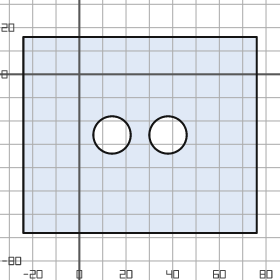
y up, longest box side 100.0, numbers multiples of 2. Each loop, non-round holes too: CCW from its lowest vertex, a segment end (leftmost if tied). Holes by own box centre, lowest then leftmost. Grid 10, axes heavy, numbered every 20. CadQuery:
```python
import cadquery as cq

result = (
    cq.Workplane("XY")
    .moveTo(-24.0, -68.0)
    .lineTo(76.0, -68.0)
    .lineTo(76.0, 16.0)
    .lineTo(-24.0, 16.0)
    .close()
    .moveTo(14.0, -26.0)
    .circle(8.0)
    .moveTo(38.0, -26.0)
    .circle(8.0)
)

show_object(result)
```